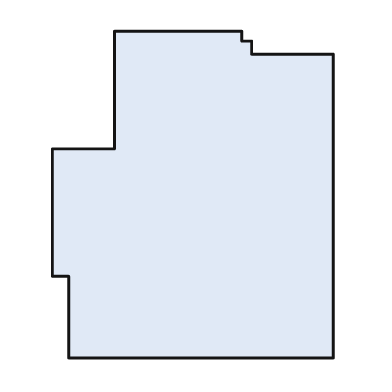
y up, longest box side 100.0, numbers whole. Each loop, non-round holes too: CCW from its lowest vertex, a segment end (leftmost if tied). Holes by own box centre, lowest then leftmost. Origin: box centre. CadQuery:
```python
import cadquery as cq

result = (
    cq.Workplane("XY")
    .moveTo(-38.0, -50.0)
    .lineTo(43.0, -50.0)
    .lineTo(43.0, 43.0)
    .lineTo(18.0, 43.0)
    .lineTo(18.0, 47.0)
    .lineTo(15.0, 47.0)
    .lineTo(15.0, 50.0)
    .lineTo(-24.0, 50.0)
    .lineTo(-24.0, 14.0)
    .lineTo(-43.0, 14.0)
    .lineTo(-43.0, -25.0)
    .lineTo(-38.0, -25.0)
    .close()
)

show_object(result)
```